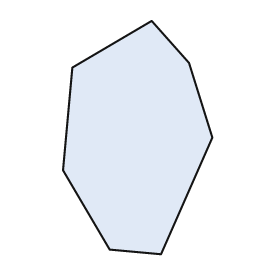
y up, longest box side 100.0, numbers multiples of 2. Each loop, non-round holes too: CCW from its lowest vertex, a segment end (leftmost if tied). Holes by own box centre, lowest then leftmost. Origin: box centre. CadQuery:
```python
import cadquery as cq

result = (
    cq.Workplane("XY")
    .moveTo(10.0, -50.0)
    .lineTo(32.0, 0.0)
    .lineTo(22.0, 32.0)
    .lineTo(6.0, 50.0)
    .lineTo(-28.0, 30.0)
    .lineTo(-32.0, -14.0)
    .lineTo(-12.0, -48.0)
    .close()
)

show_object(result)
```